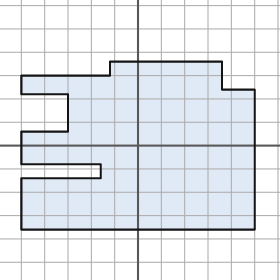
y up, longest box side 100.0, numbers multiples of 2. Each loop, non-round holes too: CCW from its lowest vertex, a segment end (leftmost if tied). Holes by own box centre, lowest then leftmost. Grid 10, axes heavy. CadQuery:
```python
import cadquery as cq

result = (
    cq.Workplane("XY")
    .moveTo(-50.0, -36.0)
    .lineTo(50.0, -36.0)
    .lineTo(50.0, 24.0)
    .lineTo(36.0, 24.0)
    .lineTo(36.0, 36.0)
    .lineTo(-12.0, 36.0)
    .lineTo(-12.0, 30.0)
    .lineTo(-50.0, 30.0)
    .lineTo(-50.0, 22.0)
    .lineTo(-30.0, 22.0)
    .lineTo(-30.0, 6.0)
    .lineTo(-50.0, 6.0)
    .lineTo(-50.0, -8.0)
    .lineTo(-16.0, -8.0)
    .lineTo(-16.0, -14.0)
    .lineTo(-50.0, -14.0)
    .close()
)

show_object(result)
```